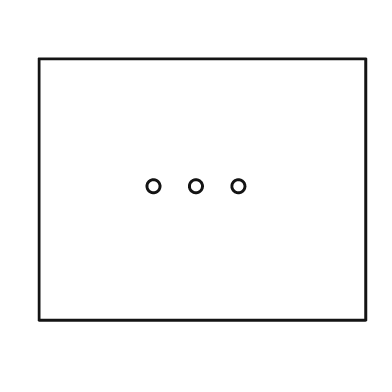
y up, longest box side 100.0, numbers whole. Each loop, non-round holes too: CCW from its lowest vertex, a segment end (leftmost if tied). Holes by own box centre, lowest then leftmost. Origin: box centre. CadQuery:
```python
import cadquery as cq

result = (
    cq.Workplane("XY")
    .moveTo(-50.0, -40.0)
    .lineTo(50.0, -40.0)
    .lineTo(50.0, 40.0)
    .lineTo(-50.0, 40.0)
    .close()
    .moveTo(-15.0, 1.0)
    .circle(2.0)
    .moveTo(-2.0, 1.0)
    .circle(2.0)
    .moveTo(11.0, 1.0)
    .circle(2.0)
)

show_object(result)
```